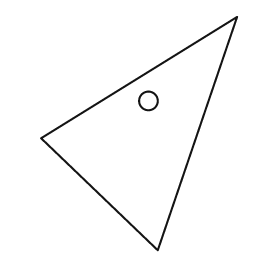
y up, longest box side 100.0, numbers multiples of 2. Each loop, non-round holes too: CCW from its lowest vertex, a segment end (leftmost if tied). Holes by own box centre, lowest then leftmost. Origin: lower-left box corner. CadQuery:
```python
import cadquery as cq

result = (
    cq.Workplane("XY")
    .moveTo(50.0, 0.0)
    .lineTo(84.0, 100.0)
    .lineTo(0.0, 48.0)
    .close()
    .moveTo(46.0, 64.0)
    .circle(4.0)
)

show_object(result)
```